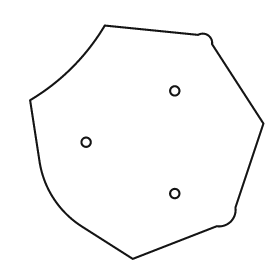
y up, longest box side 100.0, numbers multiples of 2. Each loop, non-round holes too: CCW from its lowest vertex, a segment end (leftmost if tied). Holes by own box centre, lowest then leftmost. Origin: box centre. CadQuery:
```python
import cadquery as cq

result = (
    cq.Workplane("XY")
    .moveTo(-6.0, -50.0)
    .lineTo(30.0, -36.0)
    .threePointArc((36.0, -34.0), (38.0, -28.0))
    .lineTo(50.0, 8.0)
    .lineTo(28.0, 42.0)
    .threePointArc((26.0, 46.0), (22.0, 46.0))
    .lineTo(-18.0, 50.0)
    .threePointArc((-32.0, 32.0), (-50.0, 18.0))
    .lineTo(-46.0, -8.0)
    .threePointArc((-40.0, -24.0), (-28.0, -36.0))
    .close()
    .moveTo(12.0, -22.0)
    .circle(2.0)
    .moveTo(-26.0, 0.0)
    .circle(2.0)
    .moveTo(12.0, 22.0)
    .circle(2.0)
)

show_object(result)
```